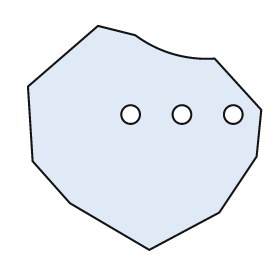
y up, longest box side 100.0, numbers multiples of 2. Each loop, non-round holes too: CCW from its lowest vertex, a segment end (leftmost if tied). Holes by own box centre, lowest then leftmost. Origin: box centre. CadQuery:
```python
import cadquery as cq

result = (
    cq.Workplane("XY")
    .moveTo(2.0, -48.0)
    .lineTo(32.0, -32.0)
    .lineTo(48.0, -8.0)
    .lineTo(50.0, 12.0)
    .lineTo(30.0, 34.0)
    .threePointArc((12.0, 36.0), (-4.0, 44.0))
    .lineTo(-20.0, 48.0)
    .lineTo(-50.0, 22.0)
    .lineTo(-48.0, -10.0)
    .lineTo(-32.0, -28.0)
    .close()
    .moveTo(-6.0, 10.0)
    .circle(4.0)
    .moveTo(16.0, 10.0)
    .circle(4.0)
    .moveTo(38.0, 10.0)
    .circle(4.0)
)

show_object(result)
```